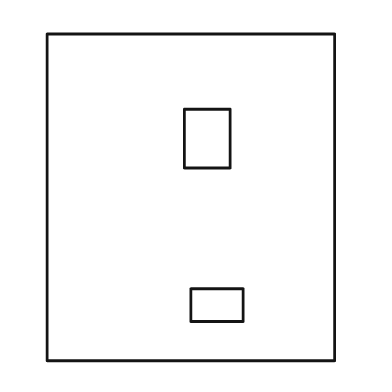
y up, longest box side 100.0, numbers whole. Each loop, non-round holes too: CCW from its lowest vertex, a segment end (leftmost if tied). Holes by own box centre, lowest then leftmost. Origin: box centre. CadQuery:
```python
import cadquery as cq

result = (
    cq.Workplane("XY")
    .moveTo(-44.0, -50.0)
    .lineTo(44.0, -50.0)
    .lineTo(44.0, 50.0)
    .lineTo(-44.0, 50.0)
    .close()
    .moveTo(0.0, -38.0)
    .lineTo(16.0, -38.0)
    .lineTo(16.0, -28.0)
    .lineTo(0.0, -28.0)
    .close()
    .moveTo(-2.0, 9.0)
    .lineTo(12.0, 9.0)
    .lineTo(12.0, 27.0)
    .lineTo(-2.0, 27.0)
    .close()
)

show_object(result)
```